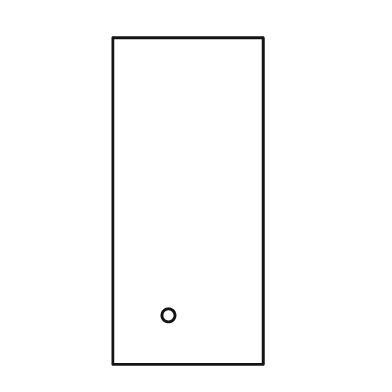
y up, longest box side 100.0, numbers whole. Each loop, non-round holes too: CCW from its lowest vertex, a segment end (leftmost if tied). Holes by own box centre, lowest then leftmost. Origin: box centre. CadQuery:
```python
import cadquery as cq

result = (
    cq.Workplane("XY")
    .moveTo(-23.0, -50.0)
    .lineTo(23.0, -50.0)
    .lineTo(23.0, 50.0)
    .lineTo(-23.0, 50.0)
    .close()
    .moveTo(-6.0, -35.0)
    .circle(2.0)
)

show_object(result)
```